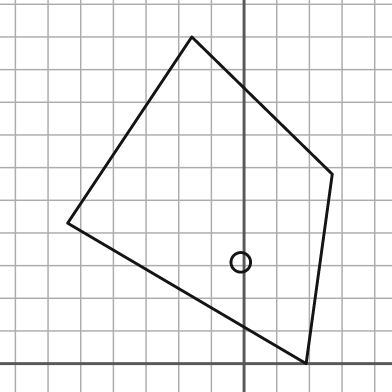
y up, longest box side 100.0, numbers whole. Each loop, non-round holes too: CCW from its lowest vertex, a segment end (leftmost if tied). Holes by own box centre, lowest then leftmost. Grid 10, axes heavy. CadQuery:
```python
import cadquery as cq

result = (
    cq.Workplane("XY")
    .moveTo(19.0, 0.0)
    .lineTo(27.0, 58.0)
    .lineTo(-16.0, 100.0)
    .lineTo(-54.0, 43.0)
    .close()
    .moveTo(-1.0, 31.0)
    .circle(3.0)
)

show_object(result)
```